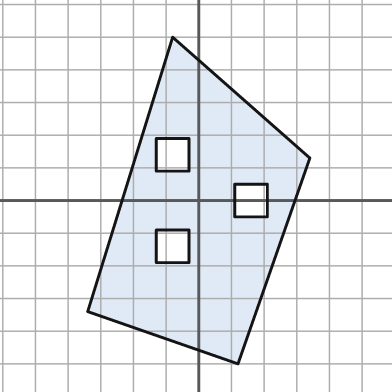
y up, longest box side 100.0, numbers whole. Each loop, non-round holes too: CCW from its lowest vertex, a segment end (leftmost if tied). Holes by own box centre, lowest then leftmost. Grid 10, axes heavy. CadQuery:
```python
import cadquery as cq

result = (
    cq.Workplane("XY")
    .moveTo(12.0, -50.0)
    .lineTo(34.0, 13.0)
    .lineTo(-8.0, 50.0)
    .lineTo(-34.0, -34.0)
    .close()
    .moveTo(-13.0, -19.0)
    .lineTo(-3.0, -19.0)
    .lineTo(-3.0, -9.0)
    .lineTo(-13.0, -9.0)
    .close()
    .moveTo(11.0, -5.0)
    .lineTo(21.0, -5.0)
    .lineTo(21.0, 5.0)
    .lineTo(11.0, 5.0)
    .close()
    .moveTo(-13.0, 9.0)
    .lineTo(-3.0, 9.0)
    .lineTo(-3.0, 19.0)
    .lineTo(-13.0, 19.0)
    .close()
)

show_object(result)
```